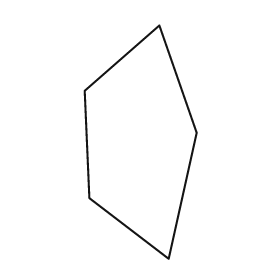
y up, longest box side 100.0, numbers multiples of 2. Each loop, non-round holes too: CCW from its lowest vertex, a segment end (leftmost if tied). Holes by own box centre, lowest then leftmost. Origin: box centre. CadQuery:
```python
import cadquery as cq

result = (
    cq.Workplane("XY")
    .moveTo(12.0, -50.0)
    .lineTo(24.0, 4.0)
    .lineTo(8.0, 50.0)
    .lineTo(-24.0, 22.0)
    .lineTo(-22.0, -24.0)
    .close()
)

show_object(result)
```